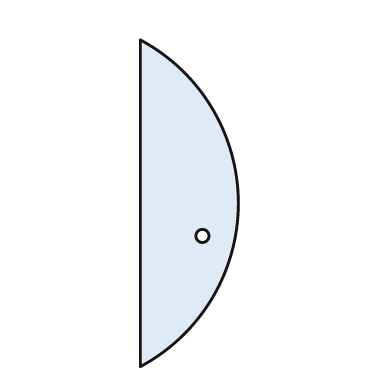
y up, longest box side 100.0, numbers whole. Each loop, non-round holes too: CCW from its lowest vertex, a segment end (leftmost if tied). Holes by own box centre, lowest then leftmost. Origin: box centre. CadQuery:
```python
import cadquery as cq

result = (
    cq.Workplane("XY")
    .moveTo(-15.0, -50.0)
    .threePointArc((15.0, 0.0), (-15.0, 50.0))
    .close()
    .moveTo(4.0, -10.0)
    .circle(2.0)
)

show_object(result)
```